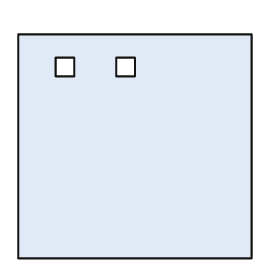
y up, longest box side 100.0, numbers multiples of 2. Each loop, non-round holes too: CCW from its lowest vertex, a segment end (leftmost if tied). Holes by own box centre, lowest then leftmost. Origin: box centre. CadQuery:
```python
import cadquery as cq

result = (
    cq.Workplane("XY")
    .moveTo(-50.0, -48.0)
    .lineTo(50.0, -48.0)
    .lineTo(50.0, 48.0)
    .lineTo(-50.0, 48.0)
    .close()
    .moveTo(-34.0, 30.0)
    .lineTo(-26.0, 30.0)
    .lineTo(-26.0, 38.0)
    .lineTo(-34.0, 38.0)
    .close()
    .moveTo(-8.0, 30.0)
    .lineTo(0.0, 30.0)
    .lineTo(0.0, 38.0)
    .lineTo(-8.0, 38.0)
    .close()
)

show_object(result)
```